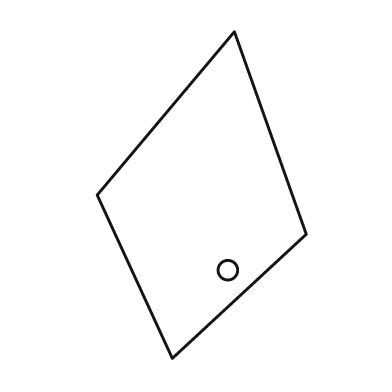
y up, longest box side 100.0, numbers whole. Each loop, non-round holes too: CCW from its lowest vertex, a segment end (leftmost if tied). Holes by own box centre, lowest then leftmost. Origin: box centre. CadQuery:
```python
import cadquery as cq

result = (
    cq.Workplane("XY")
    .moveTo(-9.0, -50.0)
    .lineTo(32.0, -12.0)
    .lineTo(10.0, 50.0)
    .lineTo(-32.0, 0.0)
    .close()
    .moveTo(8.0, -23.0)
    .circle(3.0)
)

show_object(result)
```